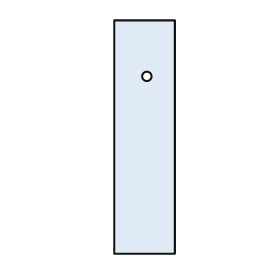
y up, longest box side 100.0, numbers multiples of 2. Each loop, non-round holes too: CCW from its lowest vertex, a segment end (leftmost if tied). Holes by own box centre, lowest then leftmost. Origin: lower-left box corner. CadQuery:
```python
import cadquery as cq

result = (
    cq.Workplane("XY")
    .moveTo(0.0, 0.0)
    .lineTo(26.0, 0.0)
    .lineTo(26.0, 100.0)
    .lineTo(0.0, 100.0)
    .close()
    .moveTo(14.0, 76.0)
    .circle(2.0)
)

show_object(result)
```